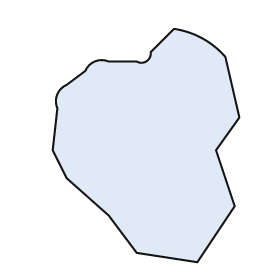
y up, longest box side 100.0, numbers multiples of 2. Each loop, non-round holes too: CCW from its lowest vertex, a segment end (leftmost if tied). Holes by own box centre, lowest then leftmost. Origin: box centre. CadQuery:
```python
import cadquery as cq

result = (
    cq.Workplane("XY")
    .moveTo(22.0, -50.0)
    .lineTo(38.0, -26.0)
    .lineTo(30.0, -2.0)
    .lineTo(40.0, 12.0)
    .lineTo(34.0, 38.0)
    .threePointArc((24.0, 46.0), (12.0, 50.0))
    .lineTo(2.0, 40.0)
    .threePointArc((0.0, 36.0), (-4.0, 36.0))
    .lineTo(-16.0, 36.0)
    .threePointArc((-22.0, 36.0), (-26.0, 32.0))
    .lineTo(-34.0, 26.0)
    .threePointArc((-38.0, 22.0), (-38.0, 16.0))
    .lineTo(-40.0, -2.0)
    .lineTo(-34.0, -14.0)
    .lineTo(-16.0, -30.0)
    .lineTo(-4.0, -46.0)
    .close()
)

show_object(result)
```